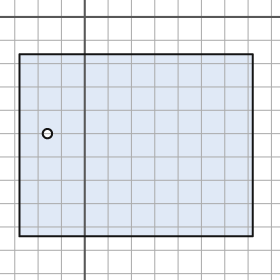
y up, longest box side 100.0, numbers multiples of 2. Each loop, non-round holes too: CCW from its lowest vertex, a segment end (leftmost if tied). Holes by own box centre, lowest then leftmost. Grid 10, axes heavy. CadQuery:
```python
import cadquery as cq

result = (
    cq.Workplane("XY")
    .moveTo(-28.0, -94.0)
    .lineTo(72.0, -94.0)
    .lineTo(72.0, -16.0)
    .lineTo(-28.0, -16.0)
    .close()
    .moveTo(-16.0, -50.0)
    .circle(2.0)
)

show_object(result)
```